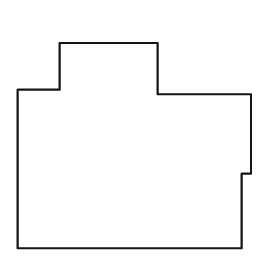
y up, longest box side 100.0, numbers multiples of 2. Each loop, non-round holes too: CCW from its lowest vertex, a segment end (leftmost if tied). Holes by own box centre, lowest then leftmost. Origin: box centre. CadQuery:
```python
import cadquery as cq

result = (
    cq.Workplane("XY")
    .moveTo(-50.0, -44.0)
    .lineTo(46.0, -44.0)
    .lineTo(46.0, -12.0)
    .lineTo(50.0, -12.0)
    .lineTo(50.0, 22.0)
    .lineTo(10.0, 22.0)
    .lineTo(10.0, 44.0)
    .lineTo(-32.0, 44.0)
    .lineTo(-32.0, 24.0)
    .lineTo(-50.0, 24.0)
    .close()
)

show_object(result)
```